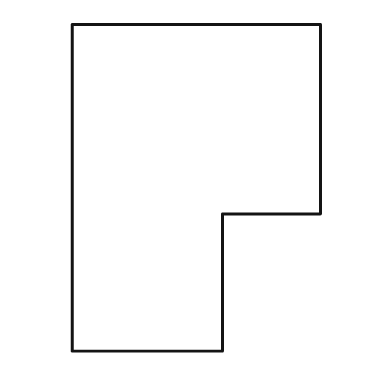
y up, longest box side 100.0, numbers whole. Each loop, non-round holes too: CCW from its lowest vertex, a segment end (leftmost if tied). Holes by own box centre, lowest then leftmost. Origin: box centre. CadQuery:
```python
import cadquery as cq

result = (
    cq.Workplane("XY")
    .moveTo(-38.0, -50.0)
    .lineTo(8.0, -50.0)
    .lineTo(8.0, -8.0)
    .lineTo(38.0, -8.0)
    .lineTo(38.0, 50.0)
    .lineTo(-38.0, 50.0)
    .close()
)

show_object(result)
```